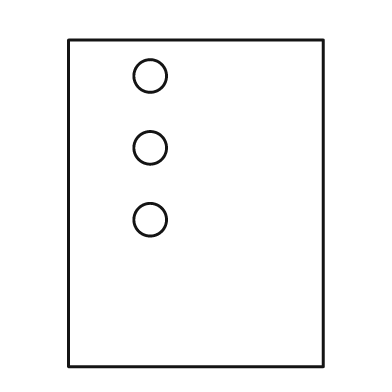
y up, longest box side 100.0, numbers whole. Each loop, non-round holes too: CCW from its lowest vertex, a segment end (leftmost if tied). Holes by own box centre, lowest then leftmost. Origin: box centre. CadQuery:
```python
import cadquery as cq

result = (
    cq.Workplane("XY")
    .moveTo(-39.0, -50.0)
    .lineTo(39.0, -50.0)
    .lineTo(39.0, 50.0)
    .lineTo(-39.0, 50.0)
    .close()
    .moveTo(-14.0, -5.0)
    .circle(5.0)
    .moveTo(-14.0, 17.0)
    .circle(5.0)
    .moveTo(-14.0, 39.0)
    .circle(5.0)
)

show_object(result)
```